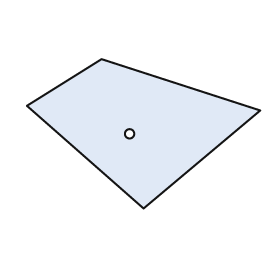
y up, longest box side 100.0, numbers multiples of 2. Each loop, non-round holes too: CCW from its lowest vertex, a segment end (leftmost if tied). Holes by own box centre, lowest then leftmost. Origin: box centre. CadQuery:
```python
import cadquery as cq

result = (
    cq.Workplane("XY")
    .moveTo(0.0, -32.0)
    .lineTo(50.0, 10.0)
    .lineTo(-18.0, 32.0)
    .lineTo(-50.0, 12.0)
    .close()
    .moveTo(-6.0, 0.0)
    .circle(2.0)
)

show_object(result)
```